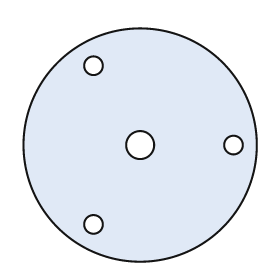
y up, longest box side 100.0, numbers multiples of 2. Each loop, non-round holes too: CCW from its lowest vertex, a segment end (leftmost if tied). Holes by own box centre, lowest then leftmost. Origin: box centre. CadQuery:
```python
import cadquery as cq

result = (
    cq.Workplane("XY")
    .moveTo(0.0, 0.0)
    .circle(50.0)
    .moveTo(-20.0, -34.0)
    .circle(4.0)
    .moveTo(0.0, 0.0)
    .circle(6.0)
    .moveTo(40.0, 0.0)
    .circle(4.0)
    .moveTo(-20.0, 34.0)
    .circle(4.0)
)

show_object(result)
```